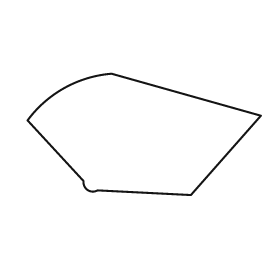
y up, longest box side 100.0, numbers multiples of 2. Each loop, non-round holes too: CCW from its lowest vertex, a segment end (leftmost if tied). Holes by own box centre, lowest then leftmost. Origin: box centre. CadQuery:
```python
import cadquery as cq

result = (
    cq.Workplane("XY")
    .moveTo(20.0, -26.0)
    .lineTo(50.0, 8.0)
    .lineTo(-14.0, 26.0)
    .threePointArc((-34.0, 20.0), (-50.0, 6.0))
    .lineTo(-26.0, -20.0)
    .threePointArc((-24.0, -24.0), (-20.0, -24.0))
    .close()
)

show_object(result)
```